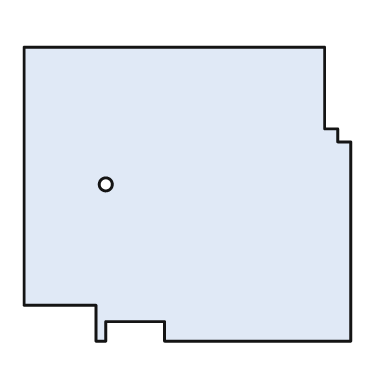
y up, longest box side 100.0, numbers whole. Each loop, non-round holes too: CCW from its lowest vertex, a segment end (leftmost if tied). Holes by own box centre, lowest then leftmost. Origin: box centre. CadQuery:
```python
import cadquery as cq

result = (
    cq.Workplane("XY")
    .moveTo(-28.0, -45.0)
    .lineTo(-25.0, -45.0)
    .lineTo(-25.0, -39.0)
    .lineTo(-7.0, -39.0)
    .lineTo(-7.0, -45.0)
    .lineTo(50.0, -45.0)
    .lineTo(50.0, 16.0)
    .lineTo(46.0, 16.0)
    .lineTo(46.0, 20.0)
    .lineTo(42.0, 20.0)
    .lineTo(42.0, 45.0)
    .lineTo(-50.0, 45.0)
    .lineTo(-50.0, -34.0)
    .lineTo(-28.0, -34.0)
    .close()
    .moveTo(-25.0, 3.0)
    .circle(2.0)
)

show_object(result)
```